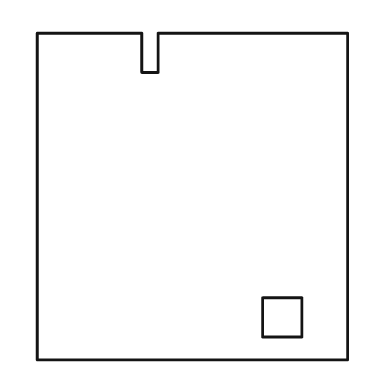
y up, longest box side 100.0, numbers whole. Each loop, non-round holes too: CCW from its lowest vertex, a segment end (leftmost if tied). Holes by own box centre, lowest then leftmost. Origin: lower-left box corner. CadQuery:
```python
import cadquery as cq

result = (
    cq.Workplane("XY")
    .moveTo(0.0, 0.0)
    .lineTo(95.0, 0.0)
    .lineTo(95.0, 100.0)
    .lineTo(37.0, 100.0)
    .lineTo(37.0, 88.0)
    .lineTo(32.0, 88.0)
    .lineTo(32.0, 100.0)
    .lineTo(0.0, 100.0)
    .close()
    .moveTo(69.0, 7.0)
    .lineTo(81.0, 7.0)
    .lineTo(81.0, 19.0)
    .lineTo(69.0, 19.0)
    .close()
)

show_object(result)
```